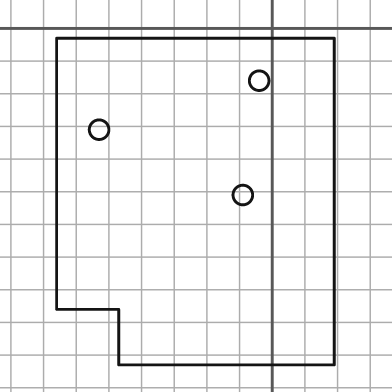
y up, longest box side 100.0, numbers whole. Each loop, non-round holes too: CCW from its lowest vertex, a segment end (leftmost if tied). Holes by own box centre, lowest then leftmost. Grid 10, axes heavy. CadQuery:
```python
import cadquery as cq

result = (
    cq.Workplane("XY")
    .moveTo(-47.0, -103.0)
    .lineTo(19.0, -103.0)
    .lineTo(19.0, -3.0)
    .lineTo(-66.0, -3.0)
    .lineTo(-66.0, -86.0)
    .lineTo(-47.0, -86.0)
    .close()
    .moveTo(-9.0, -51.0)
    .circle(3.0)
    .moveTo(-53.0, -31.0)
    .circle(3.0)
    .moveTo(-4.0, -16.0)
    .circle(3.0)
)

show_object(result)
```